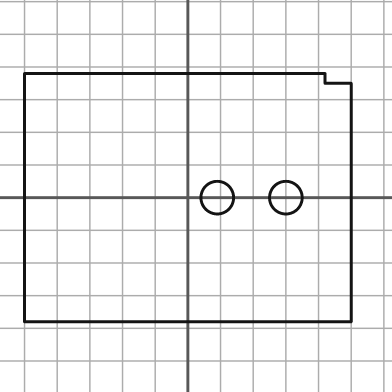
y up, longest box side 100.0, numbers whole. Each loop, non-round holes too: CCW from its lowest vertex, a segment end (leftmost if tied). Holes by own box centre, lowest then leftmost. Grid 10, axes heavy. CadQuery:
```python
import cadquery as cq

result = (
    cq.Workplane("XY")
    .moveTo(-50.0, -38.0)
    .lineTo(50.0, -38.0)
    .lineTo(50.0, 35.0)
    .lineTo(42.0, 35.0)
    .lineTo(42.0, 38.0)
    .lineTo(-50.0, 38.0)
    .close()
    .moveTo(9.0, 0.0)
    .circle(5.0)
    .moveTo(30.0, 0.0)
    .circle(5.0)
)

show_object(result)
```